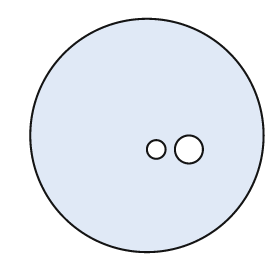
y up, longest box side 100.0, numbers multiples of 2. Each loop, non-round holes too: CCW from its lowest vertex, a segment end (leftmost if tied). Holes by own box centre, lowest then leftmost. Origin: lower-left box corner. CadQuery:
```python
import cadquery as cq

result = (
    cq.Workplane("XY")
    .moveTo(50.0, 50.0)
    .circle(50.0)
    .moveTo(54.0, 44.0)
    .circle(4.0)
    .moveTo(68.0, 44.0)
    .circle(6.0)
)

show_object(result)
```